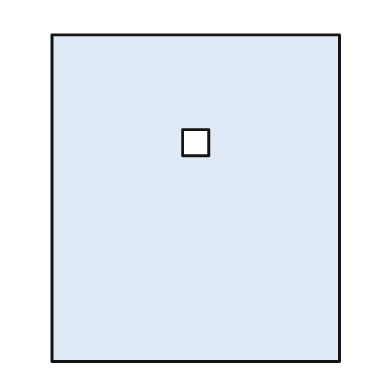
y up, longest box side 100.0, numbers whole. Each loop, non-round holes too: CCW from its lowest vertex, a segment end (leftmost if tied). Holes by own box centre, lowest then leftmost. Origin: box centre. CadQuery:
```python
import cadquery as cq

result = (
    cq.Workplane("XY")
    .moveTo(-44.0, -50.0)
    .lineTo(44.0, -50.0)
    .lineTo(44.0, 50.0)
    .lineTo(-44.0, 50.0)
    .close()
    .moveTo(-4.0, 13.0)
    .lineTo(4.0, 13.0)
    .lineTo(4.0, 21.0)
    .lineTo(-4.0, 21.0)
    .close()
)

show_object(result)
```